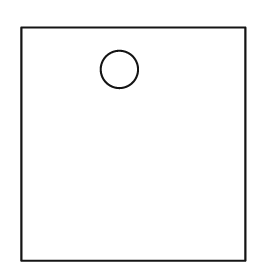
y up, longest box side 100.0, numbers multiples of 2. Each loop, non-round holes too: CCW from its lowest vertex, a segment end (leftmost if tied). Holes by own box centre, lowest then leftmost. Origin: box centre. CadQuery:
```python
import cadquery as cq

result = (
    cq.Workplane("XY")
    .moveTo(-48.0, -50.0)
    .lineTo(48.0, -50.0)
    .lineTo(48.0, 50.0)
    .lineTo(-48.0, 50.0)
    .close()
    .moveTo(-6.0, 32.0)
    .circle(8.0)
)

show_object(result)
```